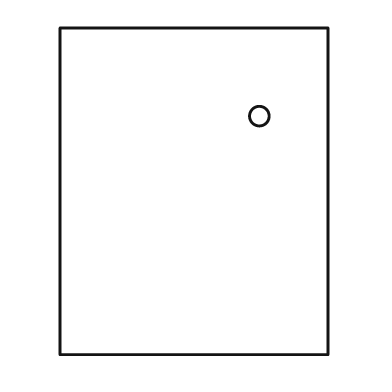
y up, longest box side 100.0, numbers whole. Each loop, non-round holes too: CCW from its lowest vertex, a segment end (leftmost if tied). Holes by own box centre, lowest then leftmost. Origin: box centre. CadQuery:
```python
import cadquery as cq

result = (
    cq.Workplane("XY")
    .moveTo(-41.0, -50.0)
    .lineTo(41.0, -50.0)
    .lineTo(41.0, 50.0)
    .lineTo(-41.0, 50.0)
    .close()
    .moveTo(20.0, 23.0)
    .circle(3.0)
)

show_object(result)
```